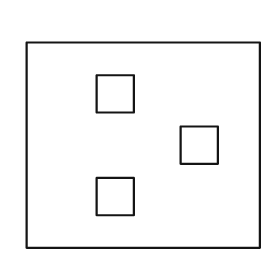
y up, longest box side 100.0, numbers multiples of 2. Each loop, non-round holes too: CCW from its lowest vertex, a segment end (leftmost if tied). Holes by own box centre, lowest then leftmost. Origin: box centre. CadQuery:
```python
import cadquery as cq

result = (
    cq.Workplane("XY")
    .moveTo(-50.0, -44.0)
    .lineTo(50.0, -44.0)
    .lineTo(50.0, 44.0)
    .lineTo(-50.0, 44.0)
    .close()
    .moveTo(-20.0, -30.0)
    .lineTo(-4.0, -30.0)
    .lineTo(-4.0, -14.0)
    .lineTo(-20.0, -14.0)
    .close()
    .moveTo(16.0, -8.0)
    .lineTo(32.0, -8.0)
    .lineTo(32.0, 8.0)
    .lineTo(16.0, 8.0)
    .close()
    .moveTo(-20.0, 14.0)
    .lineTo(-4.0, 14.0)
    .lineTo(-4.0, 30.0)
    .lineTo(-20.0, 30.0)
    .close()
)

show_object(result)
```